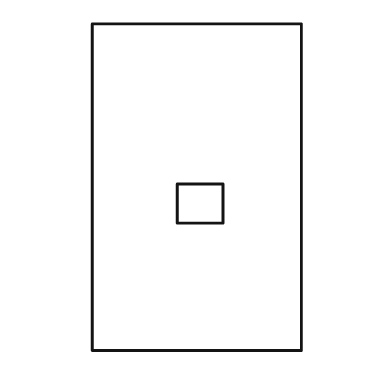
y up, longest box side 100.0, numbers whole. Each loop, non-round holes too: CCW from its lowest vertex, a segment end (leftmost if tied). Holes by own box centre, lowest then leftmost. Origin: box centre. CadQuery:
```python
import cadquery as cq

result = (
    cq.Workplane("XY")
    .moveTo(-32.0, -50.0)
    .lineTo(32.0, -50.0)
    .lineTo(32.0, 50.0)
    .lineTo(-32.0, 50.0)
    .close()
    .moveTo(-6.0, -11.0)
    .lineTo(8.0, -11.0)
    .lineTo(8.0, 1.0)
    .lineTo(-6.0, 1.0)
    .close()
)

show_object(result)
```